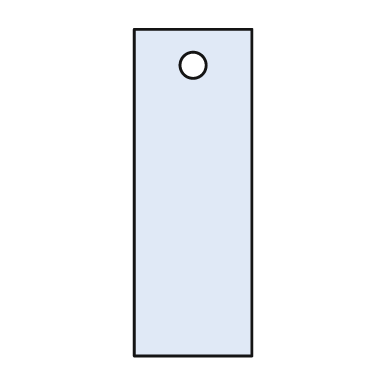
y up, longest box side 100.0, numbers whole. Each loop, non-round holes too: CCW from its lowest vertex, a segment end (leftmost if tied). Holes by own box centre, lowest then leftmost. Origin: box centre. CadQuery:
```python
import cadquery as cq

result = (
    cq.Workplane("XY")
    .moveTo(-18.0, -50.0)
    .lineTo(18.0, -50.0)
    .lineTo(18.0, 50.0)
    .lineTo(-18.0, 50.0)
    .close()
    .moveTo(0.0, 39.0)
    .circle(4.0)
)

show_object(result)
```